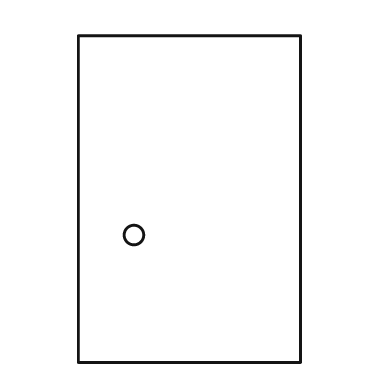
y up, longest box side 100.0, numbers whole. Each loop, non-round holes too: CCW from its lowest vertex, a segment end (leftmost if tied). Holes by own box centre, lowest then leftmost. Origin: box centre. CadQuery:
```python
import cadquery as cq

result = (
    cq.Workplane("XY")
    .moveTo(-34.0, -50.0)
    .lineTo(34.0, -50.0)
    .lineTo(34.0, 50.0)
    .lineTo(-34.0, 50.0)
    .close()
    .moveTo(-17.0, -11.0)
    .circle(3.0)
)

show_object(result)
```